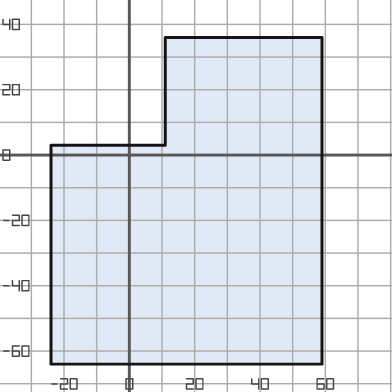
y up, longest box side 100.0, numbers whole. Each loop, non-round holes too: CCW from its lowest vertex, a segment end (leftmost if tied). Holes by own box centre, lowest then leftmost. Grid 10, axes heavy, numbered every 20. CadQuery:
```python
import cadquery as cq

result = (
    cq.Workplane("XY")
    .moveTo(-24.0, -64.0)
    .lineTo(59.0, -64.0)
    .lineTo(59.0, 36.0)
    .lineTo(11.0, 36.0)
    .lineTo(11.0, 3.0)
    .lineTo(-24.0, 3.0)
    .close()
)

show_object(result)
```